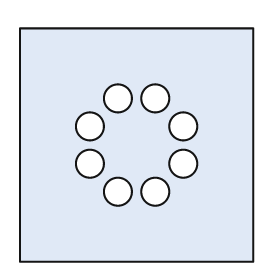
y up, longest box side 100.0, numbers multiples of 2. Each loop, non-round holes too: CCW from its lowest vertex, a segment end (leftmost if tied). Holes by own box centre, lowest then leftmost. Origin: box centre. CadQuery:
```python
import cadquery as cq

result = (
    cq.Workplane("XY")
    .moveTo(-50.0, -50.0)
    .lineTo(50.0, -50.0)
    .lineTo(50.0, 50.0)
    .lineTo(-50.0, 50.0)
    .close()
    .moveTo(-8.0, -20.0)
    .circle(6.0)
    .moveTo(8.0, -20.0)
    .circle(6.0)
    .moveTo(-20.0, -8.0)
    .circle(6.0)
    .moveTo(20.0, -8.0)
    .circle(6.0)
    .moveTo(-20.0, 8.0)
    .circle(6.0)
    .moveTo(20.0, 8.0)
    .circle(6.0)
    .moveTo(-8.0, 20.0)
    .circle(6.0)
    .moveTo(8.0, 20.0)
    .circle(6.0)
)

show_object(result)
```